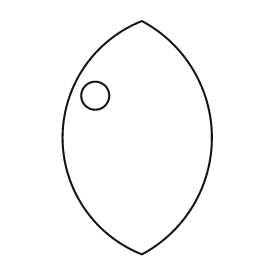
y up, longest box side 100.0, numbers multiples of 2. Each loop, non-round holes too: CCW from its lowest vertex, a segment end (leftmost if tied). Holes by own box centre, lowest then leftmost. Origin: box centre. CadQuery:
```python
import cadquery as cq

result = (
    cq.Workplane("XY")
    .moveTo(2.0, -50.0)
    .threePointArc((32.0, 0.0), (2.0, 50.0))
    .threePointArc((-32.0, 0.0), (2.0, -50.0))
    .close()
    .moveTo(-18.0, 18.0)
    .circle(6.0)
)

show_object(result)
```